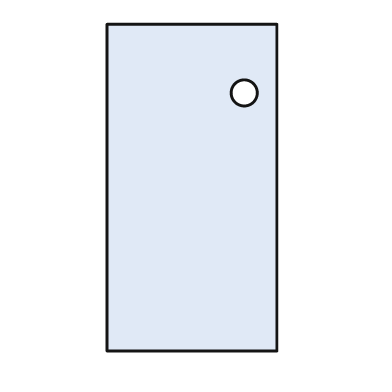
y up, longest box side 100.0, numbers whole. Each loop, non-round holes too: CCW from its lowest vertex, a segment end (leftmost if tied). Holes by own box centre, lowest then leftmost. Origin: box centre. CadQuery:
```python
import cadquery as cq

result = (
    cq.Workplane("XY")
    .moveTo(-26.0, -50.0)
    .lineTo(26.0, -50.0)
    .lineTo(26.0, 50.0)
    .lineTo(-26.0, 50.0)
    .close()
    .moveTo(16.0, 29.0)
    .circle(4.0)
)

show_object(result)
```